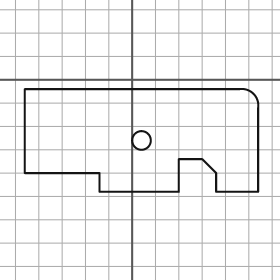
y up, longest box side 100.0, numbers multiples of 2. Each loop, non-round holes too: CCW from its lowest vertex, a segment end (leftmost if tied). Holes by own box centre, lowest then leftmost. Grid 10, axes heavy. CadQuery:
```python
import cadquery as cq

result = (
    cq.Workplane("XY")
    .moveTo(-14.0, -48.0)
    .lineTo(20.0, -48.0)
    .lineTo(20.0, -34.0)
    .lineTo(30.0, -34.0)
    .lineTo(36.0, -40.0)
    .lineTo(36.0, -48.0)
    .lineTo(54.0, -48.0)
    .lineTo(54.0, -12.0)
    .threePointArc((52.0, -6.0), (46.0, -4.0))
    .lineTo(-46.0, -4.0)
    .lineTo(-46.0, -40.0)
    .lineTo(-14.0, -40.0)
    .close()
    .moveTo(4.0, -26.0)
    .circle(4.0)
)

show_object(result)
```